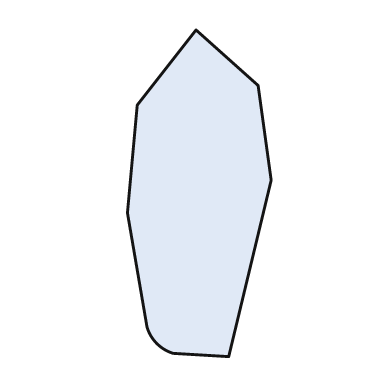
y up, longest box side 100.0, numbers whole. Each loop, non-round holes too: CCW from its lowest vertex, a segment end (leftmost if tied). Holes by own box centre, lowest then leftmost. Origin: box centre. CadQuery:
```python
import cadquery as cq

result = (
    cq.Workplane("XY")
    .moveTo(9.0, -50.0)
    .lineTo(22.0, 4.0)
    .lineTo(18.0, 33.0)
    .lineTo(-1.0, 50.0)
    .lineTo(-19.0, 27.0)
    .lineTo(-22.0, -6.0)
    .lineTo(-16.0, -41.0)
    .threePointArc((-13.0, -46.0), (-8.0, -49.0))
    .close()
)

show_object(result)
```